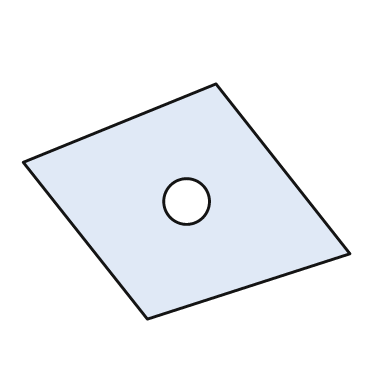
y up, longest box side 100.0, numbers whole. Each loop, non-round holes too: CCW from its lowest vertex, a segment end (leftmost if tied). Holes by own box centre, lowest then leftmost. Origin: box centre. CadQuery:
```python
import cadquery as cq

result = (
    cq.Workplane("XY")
    .moveTo(-12.0, -36.0)
    .lineTo(50.0, -16.0)
    .lineTo(9.0, 36.0)
    .lineTo(-50.0, 12.0)
    .close()
    .moveTo(0.0, 0.0)
    .circle(7.0)
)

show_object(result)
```